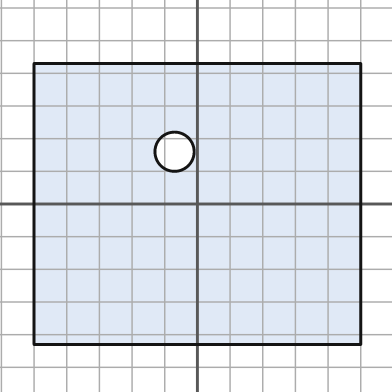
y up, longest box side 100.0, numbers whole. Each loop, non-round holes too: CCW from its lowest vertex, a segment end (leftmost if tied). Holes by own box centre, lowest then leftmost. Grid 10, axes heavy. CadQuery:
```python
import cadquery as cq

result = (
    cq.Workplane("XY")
    .moveTo(-50.0, -43.0)
    .lineTo(50.0, -43.0)
    .lineTo(50.0, 43.0)
    .lineTo(-50.0, 43.0)
    .close()
    .moveTo(-7.0, 16.0)
    .circle(6.0)
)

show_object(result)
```